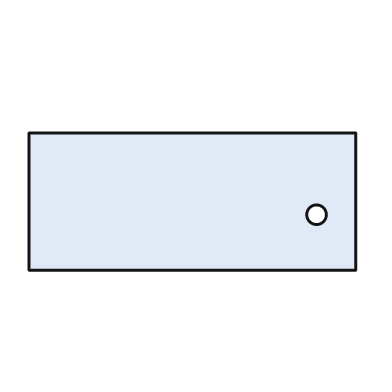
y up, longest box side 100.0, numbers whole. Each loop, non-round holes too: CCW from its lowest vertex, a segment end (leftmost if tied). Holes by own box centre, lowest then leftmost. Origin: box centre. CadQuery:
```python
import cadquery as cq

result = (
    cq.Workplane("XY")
    .moveTo(-50.0, -21.0)
    .lineTo(50.0, -21.0)
    .lineTo(50.0, 21.0)
    .lineTo(-50.0, 21.0)
    .close()
    .moveTo(38.0, -4.0)
    .circle(3.0)
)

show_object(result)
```